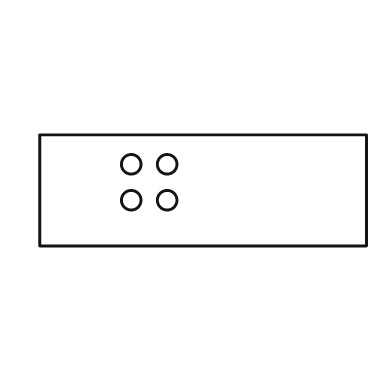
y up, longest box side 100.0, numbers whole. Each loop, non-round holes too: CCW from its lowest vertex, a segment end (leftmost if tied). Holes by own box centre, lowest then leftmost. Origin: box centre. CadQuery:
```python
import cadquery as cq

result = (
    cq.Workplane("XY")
    .moveTo(-50.0, -17.0)
    .lineTo(50.0, -17.0)
    .lineTo(50.0, 17.0)
    .lineTo(-50.0, 17.0)
    .close()
    .moveTo(-22.0, -3.0)
    .circle(3.0)
    .moveTo(-11.0, -3.0)
    .circle(3.0)
    .moveTo(-22.0, 8.0)
    .circle(3.0)
    .moveTo(-11.0, 8.0)
    .circle(3.0)
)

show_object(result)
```